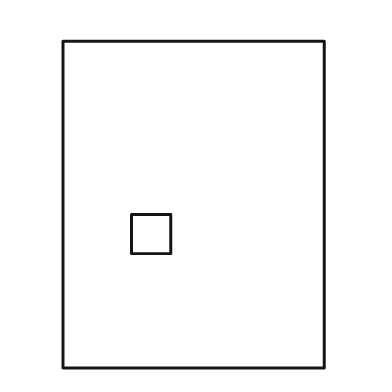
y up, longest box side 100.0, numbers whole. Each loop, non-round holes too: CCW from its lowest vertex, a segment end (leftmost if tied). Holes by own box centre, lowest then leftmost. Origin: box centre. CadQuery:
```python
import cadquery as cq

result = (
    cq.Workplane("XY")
    .moveTo(-40.0, -50.0)
    .lineTo(40.0, -50.0)
    .lineTo(40.0, 50.0)
    .lineTo(-40.0, 50.0)
    .close()
    .moveTo(-19.0, -15.0)
    .lineTo(-7.0, -15.0)
    .lineTo(-7.0, -3.0)
    .lineTo(-19.0, -3.0)
    .close()
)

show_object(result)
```